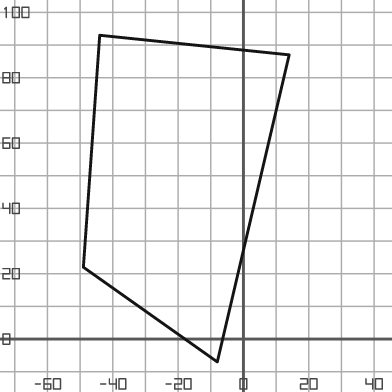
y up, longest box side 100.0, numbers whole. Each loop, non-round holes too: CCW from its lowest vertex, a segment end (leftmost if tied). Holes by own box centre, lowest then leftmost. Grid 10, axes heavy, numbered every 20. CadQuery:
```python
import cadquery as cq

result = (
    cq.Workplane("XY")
    .moveTo(-8.0, -7.0)
    .lineTo(14.0, 87.0)
    .lineTo(-44.0, 93.0)
    .lineTo(-49.0, 22.0)
    .close()
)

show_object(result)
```